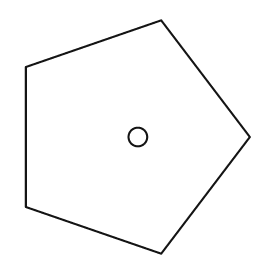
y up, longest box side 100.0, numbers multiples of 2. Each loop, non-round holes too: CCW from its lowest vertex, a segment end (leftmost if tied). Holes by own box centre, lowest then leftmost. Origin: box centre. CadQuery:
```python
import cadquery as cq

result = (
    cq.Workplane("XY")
    .moveTo(10.0, -50.0)
    .lineTo(48.0, 0.0)
    .lineTo(10.0, 50.0)
    .lineTo(-48.0, 30.0)
    .lineTo(-48.0, -30.0)
    .close()
    .moveTo(0.0, 0.0)
    .circle(4.0)
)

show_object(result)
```